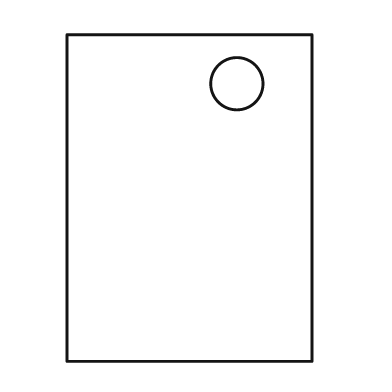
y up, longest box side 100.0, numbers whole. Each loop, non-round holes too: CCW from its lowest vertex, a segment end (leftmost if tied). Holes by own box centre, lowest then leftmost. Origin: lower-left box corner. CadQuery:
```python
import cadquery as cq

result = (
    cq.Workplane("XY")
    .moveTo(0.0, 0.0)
    .lineTo(75.0, 0.0)
    .lineTo(75.0, 100.0)
    .lineTo(0.0, 100.0)
    .close()
    .moveTo(52.0, 85.0)
    .circle(8.0)
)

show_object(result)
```